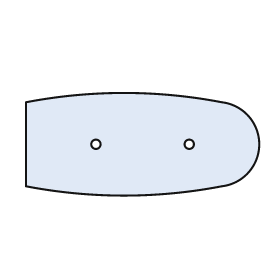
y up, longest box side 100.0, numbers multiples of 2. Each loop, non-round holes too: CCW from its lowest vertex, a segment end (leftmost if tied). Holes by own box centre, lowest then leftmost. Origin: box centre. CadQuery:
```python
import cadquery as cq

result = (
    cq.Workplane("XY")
    .moveTo(-50.0, -18.0)
    .threePointArc((-8.0, -22.0), (34.0, -18.0))
    .threePointArc((50.0, 0.0), (34.0, 18.0))
    .threePointArc((-8.0, 22.0), (-50.0, 18.0))
    .close()
    .moveTo(-20.0, 0.0)
    .circle(2.0)
    .moveTo(20.0, 0.0)
    .circle(2.0)
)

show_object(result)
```